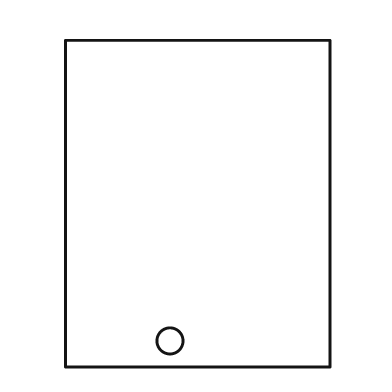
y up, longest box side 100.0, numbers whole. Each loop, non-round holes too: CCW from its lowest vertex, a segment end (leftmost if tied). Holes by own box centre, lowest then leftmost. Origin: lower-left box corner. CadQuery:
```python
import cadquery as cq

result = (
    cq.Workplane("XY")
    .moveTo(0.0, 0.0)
    .lineTo(81.0, 0.0)
    .lineTo(81.0, 100.0)
    .lineTo(0.0, 100.0)
    .close()
    .moveTo(32.0, 8.0)
    .circle(4.0)
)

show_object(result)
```